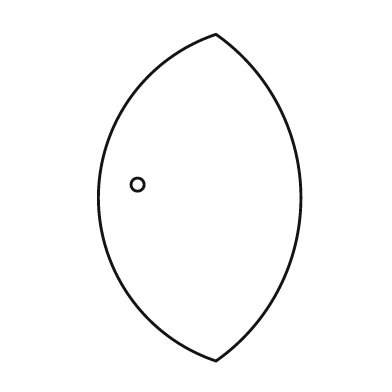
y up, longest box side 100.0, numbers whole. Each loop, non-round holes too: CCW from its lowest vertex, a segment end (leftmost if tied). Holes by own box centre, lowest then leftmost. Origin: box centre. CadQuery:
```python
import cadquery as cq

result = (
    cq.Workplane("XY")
    .moveTo(5.0, -50.0)
    .threePointArc((31.0, 0.0), (5.0, 50.0))
    .threePointArc((-31.0, 0.0), (5.0, -50.0))
    .close()
    .moveTo(-19.0, 4.0)
    .circle(2.0)
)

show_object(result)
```